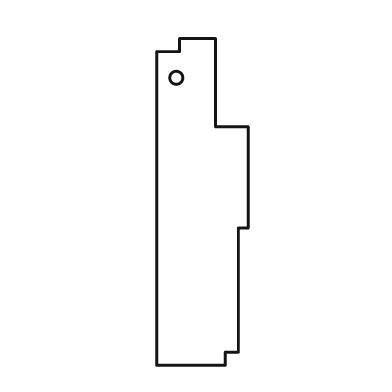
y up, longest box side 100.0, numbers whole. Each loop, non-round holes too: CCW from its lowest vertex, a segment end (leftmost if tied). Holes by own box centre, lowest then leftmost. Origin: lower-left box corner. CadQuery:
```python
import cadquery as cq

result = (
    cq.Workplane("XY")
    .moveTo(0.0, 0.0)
    .lineTo(21.0, 0.0)
    .lineTo(21.0, 4.0)
    .lineTo(25.0, 4.0)
    .lineTo(25.0, 42.0)
    .lineTo(28.0, 42.0)
    .lineTo(28.0, 73.0)
    .lineTo(18.0, 73.0)
    .lineTo(18.0, 100.0)
    .lineTo(7.0, 100.0)
    .lineTo(7.0, 96.0)
    .lineTo(0.0, 96.0)
    .close()
    .moveTo(6.0, 88.0)
    .circle(2.0)
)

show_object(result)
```